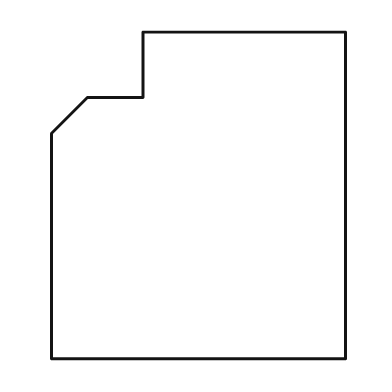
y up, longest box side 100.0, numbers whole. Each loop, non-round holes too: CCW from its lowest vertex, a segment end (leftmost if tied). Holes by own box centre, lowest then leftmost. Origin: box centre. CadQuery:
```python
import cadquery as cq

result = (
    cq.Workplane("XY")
    .moveTo(-45.0, -50.0)
    .lineTo(45.0, -50.0)
    .lineTo(45.0, 50.0)
    .lineTo(-17.0, 50.0)
    .lineTo(-17.0, 30.0)
    .lineTo(-34.0, 30.0)
    .lineTo(-45.0, 19.0)
    .close()
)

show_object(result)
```